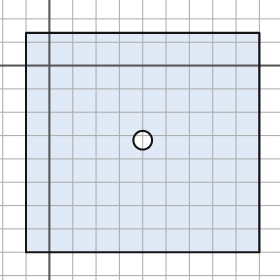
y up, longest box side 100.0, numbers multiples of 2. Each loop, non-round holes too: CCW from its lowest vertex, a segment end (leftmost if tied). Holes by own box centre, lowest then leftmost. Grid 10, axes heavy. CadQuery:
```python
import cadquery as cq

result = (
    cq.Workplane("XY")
    .moveTo(-10.0, -80.0)
    .lineTo(90.0, -80.0)
    .lineTo(90.0, 14.0)
    .lineTo(-10.0, 14.0)
    .close()
    .moveTo(40.0, -32.0)
    .circle(4.0)
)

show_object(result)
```